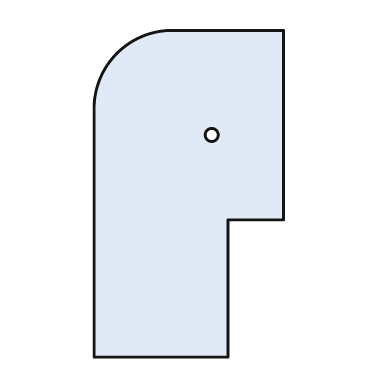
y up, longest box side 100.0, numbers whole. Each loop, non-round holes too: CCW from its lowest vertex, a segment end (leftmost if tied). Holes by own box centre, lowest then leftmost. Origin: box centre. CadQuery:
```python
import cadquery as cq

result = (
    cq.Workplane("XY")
    .moveTo(-29.0, -50.0)
    .lineTo(12.0, -50.0)
    .lineTo(12.0, -8.0)
    .lineTo(29.0, -8.0)
    .lineTo(29.0, 50.0)
    .lineTo(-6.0, 50.0)
    .threePointArc((-22.0, 43.0), (-29.0, 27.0))
    .close()
    .moveTo(7.0, 18.0)
    .circle(2.0)
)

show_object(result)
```